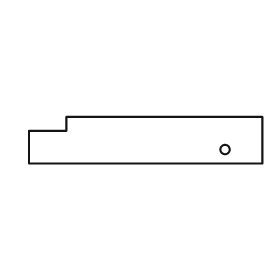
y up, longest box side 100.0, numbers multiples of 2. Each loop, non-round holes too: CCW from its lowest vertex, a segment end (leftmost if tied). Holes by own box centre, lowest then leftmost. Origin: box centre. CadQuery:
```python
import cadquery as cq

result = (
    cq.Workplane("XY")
    .moveTo(-50.0, -10.0)
    .lineTo(50.0, -10.0)
    .lineTo(50.0, 10.0)
    .lineTo(-34.0, 10.0)
    .lineTo(-34.0, 4.0)
    .lineTo(-50.0, 4.0)
    .close()
    .moveTo(34.0, -4.0)
    .circle(2.0)
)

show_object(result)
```